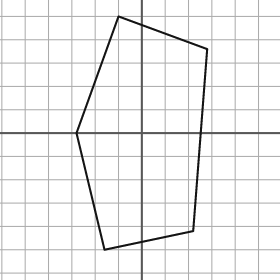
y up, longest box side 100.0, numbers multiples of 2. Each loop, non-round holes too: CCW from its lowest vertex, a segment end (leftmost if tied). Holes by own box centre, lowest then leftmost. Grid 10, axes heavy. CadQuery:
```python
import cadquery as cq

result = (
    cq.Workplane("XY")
    .moveTo(-16.0, -50.0)
    .lineTo(22.0, -42.0)
    .lineTo(28.0, 36.0)
    .lineTo(-10.0, 50.0)
    .lineTo(-28.0, 0.0)
    .close()
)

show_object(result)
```